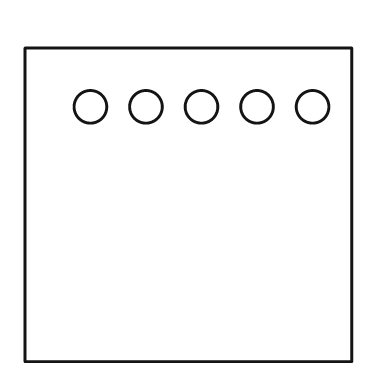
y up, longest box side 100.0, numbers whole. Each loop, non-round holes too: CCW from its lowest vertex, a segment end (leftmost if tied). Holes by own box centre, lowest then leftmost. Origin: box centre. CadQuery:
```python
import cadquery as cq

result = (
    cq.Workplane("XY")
    .moveTo(-50.0, -48.0)
    .lineTo(50.0, -48.0)
    .lineTo(50.0, 48.0)
    .lineTo(-50.0, 48.0)
    .close()
    .moveTo(-30.0, 30.0)
    .circle(5.0)
    .moveTo(-13.0, 30.0)
    .circle(5.0)
    .moveTo(4.0, 30.0)
    .circle(5.0)
    .moveTo(21.0, 30.0)
    .circle(5.0)
    .moveTo(38.0, 30.0)
    .circle(5.0)
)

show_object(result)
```